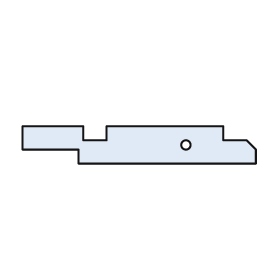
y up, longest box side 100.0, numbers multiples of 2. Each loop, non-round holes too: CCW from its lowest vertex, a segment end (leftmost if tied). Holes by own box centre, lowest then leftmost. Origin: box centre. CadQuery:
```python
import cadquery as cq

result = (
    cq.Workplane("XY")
    .moveTo(-26.0, -8.0)
    .lineTo(50.0, -8.0)
    .lineTo(50.0, -2.0)
    .lineTo(46.0, 2.0)
    .lineTo(36.0, 2.0)
    .lineTo(36.0, 8.0)
    .lineTo(-14.0, 8.0)
    .lineTo(-14.0, 2.0)
    .lineTo(-24.0, 2.0)
    .lineTo(-24.0, 8.0)
    .lineTo(-50.0, 8.0)
    .lineTo(-50.0, -2.0)
    .lineTo(-26.0, -2.0)
    .close()
    .moveTo(20.0, 0.0)
    .circle(2.0)
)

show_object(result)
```